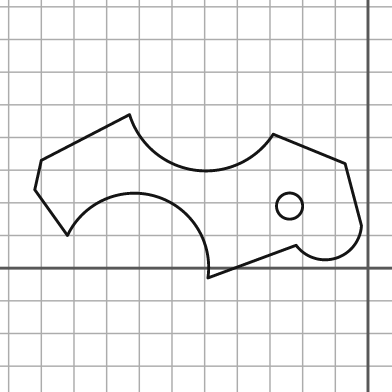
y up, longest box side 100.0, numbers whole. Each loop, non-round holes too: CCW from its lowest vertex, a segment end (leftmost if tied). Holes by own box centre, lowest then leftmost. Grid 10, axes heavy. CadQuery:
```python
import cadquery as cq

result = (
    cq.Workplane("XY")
    .moveTo(-49.0, -3.0)
    .lineTo(-22.0, 7.0)
    .threePointArc((-10.0, 3.0), (-2.0, 13.0))
    .lineTo(-7.0, 32.0)
    .lineTo(-29.0, 41.0)
    .threePointArc((-53.0, 30.0), (-73.0, 47.0))
    .lineTo(-100.0, 33.0)
    .lineTo(-102.0, 24.0)
    .lineTo(-92.0, 10.0)
    .threePointArc((-65.0, 22.0), (-49.0, -3.0))
    .close()
    .moveTo(-24.0, 19.0)
    .circle(4.0)
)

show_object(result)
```